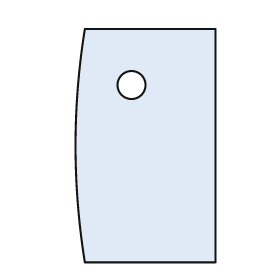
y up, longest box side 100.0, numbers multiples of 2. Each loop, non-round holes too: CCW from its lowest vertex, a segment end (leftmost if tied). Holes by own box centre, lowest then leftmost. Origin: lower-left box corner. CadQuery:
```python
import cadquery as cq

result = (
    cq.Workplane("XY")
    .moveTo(4.0, 0.0)
    .lineTo(60.0, 0.0)
    .lineTo(60.0, 100.0)
    .lineTo(4.0, 100.0)
    .threePointArc((0.0, 50.0), (4.0, 0.0))
    .close()
    .moveTo(24.0, 76.0)
    .circle(6.0)
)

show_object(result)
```